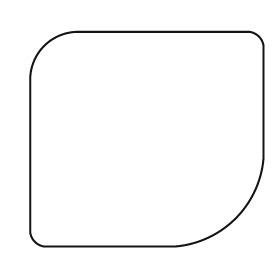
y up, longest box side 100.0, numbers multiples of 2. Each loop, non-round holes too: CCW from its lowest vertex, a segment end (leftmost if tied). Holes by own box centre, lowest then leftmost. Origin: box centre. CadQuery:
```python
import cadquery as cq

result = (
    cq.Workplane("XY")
    .moveTo(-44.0, -46.0)
    .lineTo(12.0, -46.0)
    .threePointArc((38.0, -34.0), (50.0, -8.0))
    .lineTo(50.0, 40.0)
    .threePointArc((48.0, 44.0), (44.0, 46.0))
    .lineTo(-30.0, 46.0)
    .threePointArc((-44.0, 40.0), (-50.0, 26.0))
    .lineTo(-50.0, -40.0)
    .threePointArc((-48.0, -44.0), (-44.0, -46.0))
    .close()
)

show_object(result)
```